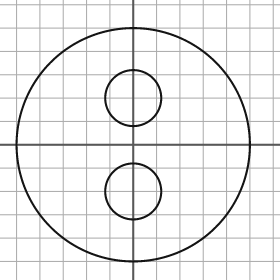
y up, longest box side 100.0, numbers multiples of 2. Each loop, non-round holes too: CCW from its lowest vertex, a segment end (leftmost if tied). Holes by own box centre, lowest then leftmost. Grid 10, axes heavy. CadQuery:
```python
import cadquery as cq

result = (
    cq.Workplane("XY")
    .moveTo(0.0, 0.0)
    .circle(50.0)
    .moveTo(0.0, -20.0)
    .circle(12.0)
    .moveTo(0.0, 20.0)
    .circle(12.0)
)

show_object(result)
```